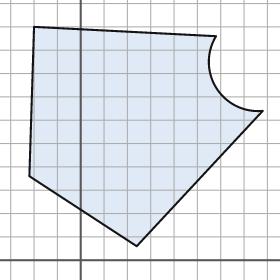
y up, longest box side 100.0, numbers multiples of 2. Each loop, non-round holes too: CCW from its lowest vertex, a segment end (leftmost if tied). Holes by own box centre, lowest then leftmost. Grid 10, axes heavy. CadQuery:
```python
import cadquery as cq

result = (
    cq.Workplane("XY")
    .moveTo(24.0, 6.0)
    .lineTo(78.0, 64.0)
    .threePointArc((58.0, 74.0), (58.0, 96.0))
    .lineTo(-20.0, 100.0)
    .lineTo(-22.0, 36.0)
    .close()
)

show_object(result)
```